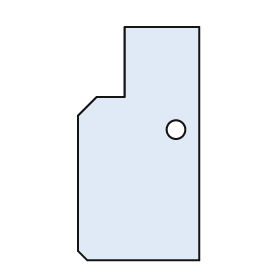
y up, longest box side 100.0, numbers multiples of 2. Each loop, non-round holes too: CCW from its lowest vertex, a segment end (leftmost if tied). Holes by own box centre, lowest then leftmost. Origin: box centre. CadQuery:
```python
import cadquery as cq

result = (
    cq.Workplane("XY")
    .moveTo(-22.0, -50.0)
    .lineTo(26.0, -50.0)
    .lineTo(26.0, 50.0)
    .lineTo(-6.0, 50.0)
    .lineTo(-6.0, 20.0)
    .lineTo(-18.0, 20.0)
    .lineTo(-26.0, 12.0)
    .lineTo(-26.0, -46.0)
    .close()
    .moveTo(16.0, 6.0)
    .circle(4.0)
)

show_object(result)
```